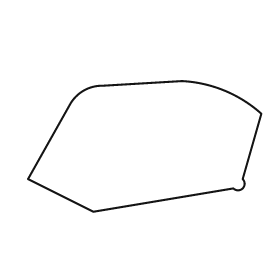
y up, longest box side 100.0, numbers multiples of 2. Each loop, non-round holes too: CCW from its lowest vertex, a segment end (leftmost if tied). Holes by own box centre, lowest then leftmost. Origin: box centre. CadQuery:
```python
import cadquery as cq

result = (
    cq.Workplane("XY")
    .moveTo(-22.0, -28.0)
    .lineTo(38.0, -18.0)
    .threePointArc((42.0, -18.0), (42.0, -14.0))
    .lineTo(50.0, 14.0)
    .threePointArc((34.0, 24.0), (16.0, 28.0))
    .lineTo(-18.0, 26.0)
    .threePointArc((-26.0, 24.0), (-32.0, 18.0))
    .lineTo(-50.0, -14.0)
    .close()
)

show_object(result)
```